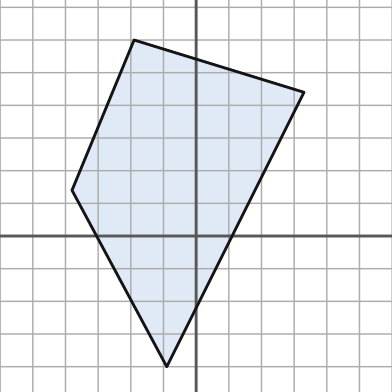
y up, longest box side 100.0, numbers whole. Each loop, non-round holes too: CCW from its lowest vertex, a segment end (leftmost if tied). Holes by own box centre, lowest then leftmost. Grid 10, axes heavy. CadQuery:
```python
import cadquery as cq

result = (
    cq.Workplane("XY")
    .moveTo(-9.0, -40.0)
    .lineTo(33.0, 44.0)
    .lineTo(-19.0, 60.0)
    .lineTo(-38.0, 14.0)
    .close()
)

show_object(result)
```